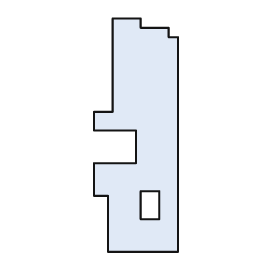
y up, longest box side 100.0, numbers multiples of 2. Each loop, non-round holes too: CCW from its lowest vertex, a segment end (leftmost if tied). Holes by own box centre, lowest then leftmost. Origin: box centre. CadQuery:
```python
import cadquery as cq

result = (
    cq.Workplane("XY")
    .moveTo(-12.0, -50.0)
    .lineTo(18.0, -50.0)
    .lineTo(18.0, 42.0)
    .lineTo(14.0, 42.0)
    .lineTo(14.0, 46.0)
    .lineTo(2.0, 46.0)
    .lineTo(2.0, 50.0)
    .lineTo(-10.0, 50.0)
    .lineTo(-10.0, 10.0)
    .lineTo(-18.0, 10.0)
    .lineTo(-18.0, 2.0)
    .lineTo(0.0, 2.0)
    .lineTo(0.0, -12.0)
    .lineTo(-18.0, -12.0)
    .lineTo(-18.0, -26.0)
    .lineTo(-12.0, -26.0)
    .close()
    .moveTo(2.0, -36.0)
    .lineTo(10.0, -36.0)
    .lineTo(10.0, -24.0)
    .lineTo(2.0, -24.0)
    .close()
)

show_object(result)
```